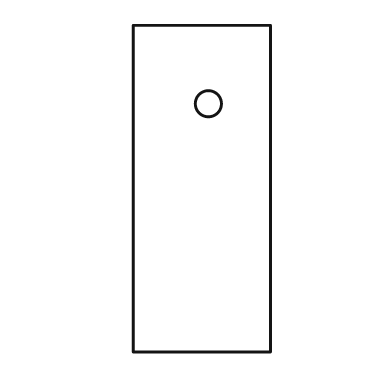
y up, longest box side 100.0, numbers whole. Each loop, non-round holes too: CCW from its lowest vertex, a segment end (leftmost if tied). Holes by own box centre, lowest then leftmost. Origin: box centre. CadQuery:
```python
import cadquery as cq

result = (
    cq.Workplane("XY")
    .moveTo(-21.0, -50.0)
    .lineTo(21.0, -50.0)
    .lineTo(21.0, 50.0)
    .lineTo(-21.0, 50.0)
    .close()
    .moveTo(2.0, 26.0)
    .circle(4.0)
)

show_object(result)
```